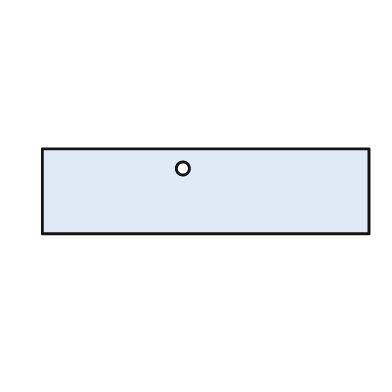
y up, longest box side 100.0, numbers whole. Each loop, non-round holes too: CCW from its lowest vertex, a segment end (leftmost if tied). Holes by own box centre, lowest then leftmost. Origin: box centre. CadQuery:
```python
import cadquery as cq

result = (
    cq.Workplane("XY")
    .moveTo(-50.0, -13.0)
    .lineTo(50.0, -13.0)
    .lineTo(50.0, 13.0)
    .lineTo(-50.0, 13.0)
    .close()
    .moveTo(-7.0, 7.0)
    .circle(2.0)
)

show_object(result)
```